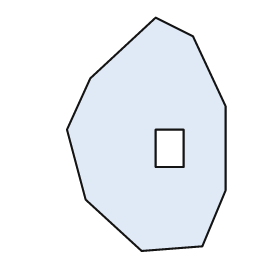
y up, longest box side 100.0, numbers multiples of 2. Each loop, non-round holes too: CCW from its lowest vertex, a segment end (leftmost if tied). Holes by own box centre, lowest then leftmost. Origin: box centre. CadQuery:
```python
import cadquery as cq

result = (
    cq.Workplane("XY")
    .moveTo(-2.0, -50.0)
    .lineTo(24.0, -48.0)
    .lineTo(34.0, -24.0)
    .lineTo(34.0, 12.0)
    .lineTo(20.0, 42.0)
    .lineTo(4.0, 50.0)
    .lineTo(-24.0, 24.0)
    .lineTo(-34.0, 2.0)
    .lineTo(-26.0, -28.0)
    .close()
    .moveTo(4.0, -14.0)
    .lineTo(16.0, -14.0)
    .lineTo(16.0, 2.0)
    .lineTo(4.0, 2.0)
    .close()
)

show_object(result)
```